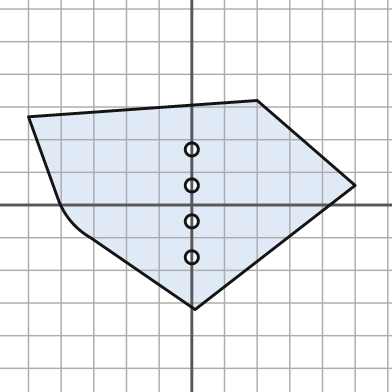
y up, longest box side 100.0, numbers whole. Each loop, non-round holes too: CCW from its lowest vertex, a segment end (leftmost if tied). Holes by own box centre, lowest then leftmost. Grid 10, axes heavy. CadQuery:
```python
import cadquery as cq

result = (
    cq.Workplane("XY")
    .moveTo(1.0, -32.0)
    .lineTo(50.0, 6.0)
    .lineTo(20.0, 32.0)
    .lineTo(-50.0, 27.0)
    .lineTo(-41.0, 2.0)
    .threePointArc((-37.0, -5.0), (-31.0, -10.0))
    .close()
    .moveTo(0.0, -16.0)
    .circle(2.0)
    .moveTo(0.0, -5.0)
    .circle(2.0)
    .moveTo(0.0, 6.0)
    .circle(2.0)
    .moveTo(0.0, 17.0)
    .circle(2.0)
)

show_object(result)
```